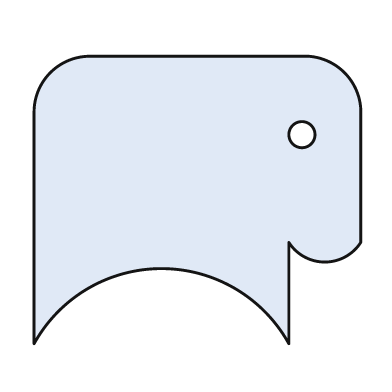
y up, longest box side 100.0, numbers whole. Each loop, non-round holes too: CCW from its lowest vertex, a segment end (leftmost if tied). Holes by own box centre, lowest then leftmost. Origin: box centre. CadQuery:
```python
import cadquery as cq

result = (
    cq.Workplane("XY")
    .moveTo(-50.0, -44.0)
    .threePointArc((-11.0, -21.0), (28.0, -44.0))
    .lineTo(28.0, -13.0)
    .threePointArc((39.0, -19.0), (50.0, -13.0))
    .lineTo(50.0, 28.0)
    .threePointArc((45.0, 39.0), (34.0, 44.0))
    .lineTo(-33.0, 44.0)
    .threePointArc((-45.0, 39.0), (-50.0, 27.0))
    .close()
    .moveTo(32.0, 20.0)
    .circle(4.0)
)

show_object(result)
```